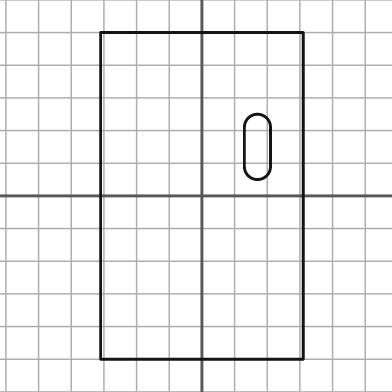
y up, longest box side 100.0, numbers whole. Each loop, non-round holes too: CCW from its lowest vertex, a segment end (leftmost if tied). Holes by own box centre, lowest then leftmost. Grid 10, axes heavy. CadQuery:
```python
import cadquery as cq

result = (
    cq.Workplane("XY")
    .moveTo(-31.0, -50.0)
    .lineTo(31.0, -50.0)
    .lineTo(31.0, 50.0)
    .lineTo(-31.0, 50.0)
    .close()
    .moveTo(13.0, 9.0)
    .threePointArc((17.0, 5.0), (21.0, 9.0))
    .lineTo(21.0, 21.0)
    .threePointArc((17.0, 25.0), (13.0, 21.0))
    .close()
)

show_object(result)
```